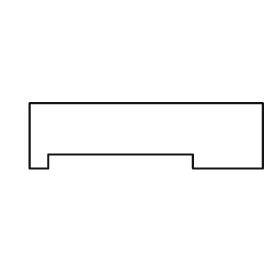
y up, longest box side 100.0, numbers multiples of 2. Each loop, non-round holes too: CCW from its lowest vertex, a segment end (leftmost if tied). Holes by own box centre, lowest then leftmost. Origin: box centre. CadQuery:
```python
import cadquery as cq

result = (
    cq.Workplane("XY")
    .moveTo(-50.0, -14.0)
    .lineTo(-42.0, -14.0)
    .lineTo(-42.0, -8.0)
    .lineTo(20.0, -8.0)
    .lineTo(20.0, -14.0)
    .lineTo(50.0, -14.0)
    .lineTo(50.0, 14.0)
    .lineTo(-50.0, 14.0)
    .close()
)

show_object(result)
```